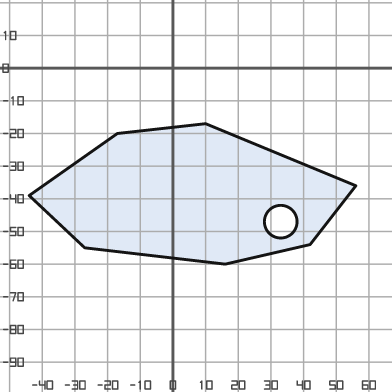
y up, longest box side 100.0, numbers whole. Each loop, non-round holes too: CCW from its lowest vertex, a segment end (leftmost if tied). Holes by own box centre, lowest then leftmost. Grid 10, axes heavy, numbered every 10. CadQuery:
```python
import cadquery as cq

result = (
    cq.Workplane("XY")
    .moveTo(16.0, -60.0)
    .lineTo(42.0, -54.0)
    .lineTo(56.0, -36.0)
    .lineTo(10.0, -17.0)
    .lineTo(-17.0, -20.0)
    .lineTo(-44.0, -39.0)
    .lineTo(-27.0, -55.0)
    .close()
    .moveTo(33.0, -47.0)
    .circle(5.0)
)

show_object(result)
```